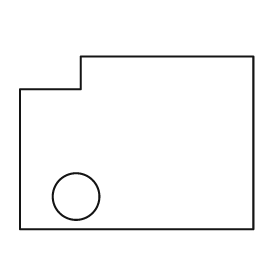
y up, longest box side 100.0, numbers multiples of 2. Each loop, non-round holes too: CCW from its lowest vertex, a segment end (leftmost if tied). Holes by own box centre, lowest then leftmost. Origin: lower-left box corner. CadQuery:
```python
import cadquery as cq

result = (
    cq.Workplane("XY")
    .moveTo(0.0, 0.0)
    .lineTo(100.0, 0.0)
    .lineTo(100.0, 74.0)
    .lineTo(26.0, 74.0)
    .lineTo(26.0, 60.0)
    .lineTo(0.0, 60.0)
    .close()
    .moveTo(24.0, 14.0)
    .circle(10.0)
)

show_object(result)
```